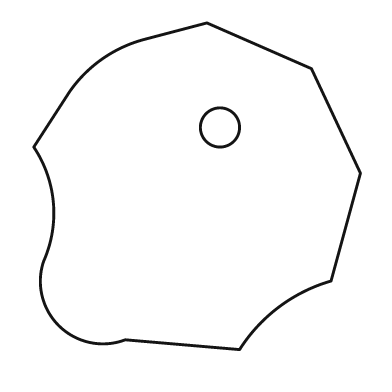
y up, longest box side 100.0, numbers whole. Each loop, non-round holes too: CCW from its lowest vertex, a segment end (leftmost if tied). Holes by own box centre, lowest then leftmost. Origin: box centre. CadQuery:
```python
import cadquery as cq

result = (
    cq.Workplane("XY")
    .moveTo(13.0, -50.0)
    .threePointArc((25.0, -37.0), (41.0, -29.0))
    .lineTo(50.0, 4.0)
    .lineTo(35.0, 36.0)
    .lineTo(3.0, 50.0)
    .lineTo(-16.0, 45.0)
    .threePointArc((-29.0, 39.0), (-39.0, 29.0))
    .lineTo(-50.0, 12.0)
    .threePointArc((-44.0, -5.0), (-47.0, -23.0))
    .threePointArc((-42.0, -43.0), (-22.0, -47.0))
    .close()
    .moveTo(7.0, 18.0)
    .circle(6.0)
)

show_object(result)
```